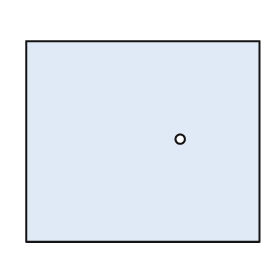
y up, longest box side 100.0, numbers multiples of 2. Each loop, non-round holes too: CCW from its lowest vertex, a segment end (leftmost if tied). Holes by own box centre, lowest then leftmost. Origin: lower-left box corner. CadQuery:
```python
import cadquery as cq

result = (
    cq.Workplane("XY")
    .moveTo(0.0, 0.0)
    .lineTo(100.0, 0.0)
    .lineTo(100.0, 86.0)
    .lineTo(0.0, 86.0)
    .close()
    .moveTo(66.0, 44.0)
    .circle(2.0)
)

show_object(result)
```